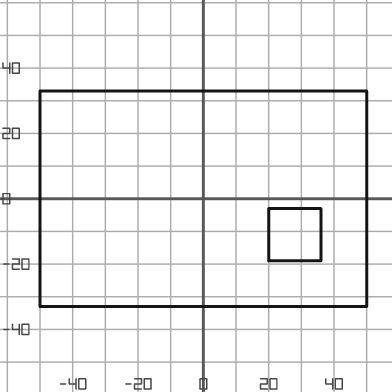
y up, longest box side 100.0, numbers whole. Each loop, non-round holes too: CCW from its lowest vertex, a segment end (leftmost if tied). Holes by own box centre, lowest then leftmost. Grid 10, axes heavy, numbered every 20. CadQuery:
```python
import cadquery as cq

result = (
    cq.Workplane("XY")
    .moveTo(-50.0, -33.0)
    .lineTo(50.0, -33.0)
    .lineTo(50.0, 33.0)
    .lineTo(-50.0, 33.0)
    .close()
    .moveTo(20.0, -19.0)
    .lineTo(36.0, -19.0)
    .lineTo(36.0, -3.0)
    .lineTo(20.0, -3.0)
    .close()
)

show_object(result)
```